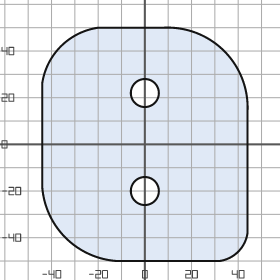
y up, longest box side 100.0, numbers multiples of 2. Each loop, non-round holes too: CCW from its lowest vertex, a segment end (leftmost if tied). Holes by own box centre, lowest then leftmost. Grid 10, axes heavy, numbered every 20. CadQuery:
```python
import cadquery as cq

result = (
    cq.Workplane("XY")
    .moveTo(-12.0, -50.0)
    .lineTo(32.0, -50.0)
    .threePointArc((40.0, -46.0), (44.0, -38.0))
    .lineTo(44.0, 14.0)
    .threePointArc((34.0, 40.0), (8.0, 50.0))
    .lineTo(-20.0, 50.0)
    .threePointArc((-36.0, 42.0), (-44.0, 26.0))
    .lineTo(-44.0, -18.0)
    .threePointArc((-34.0, -40.0), (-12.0, -50.0))
    .close()
    .moveTo(0.0, -20.0)
    .circle(6.0)
    .moveTo(0.0, 22.0)
    .circle(6.0)
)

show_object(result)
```